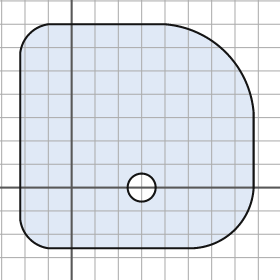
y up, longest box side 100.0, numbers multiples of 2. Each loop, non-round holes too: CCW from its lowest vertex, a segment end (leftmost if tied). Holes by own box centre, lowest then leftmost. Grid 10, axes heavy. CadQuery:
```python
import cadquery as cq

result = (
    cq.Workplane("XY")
    .moveTo(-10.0, -26.0)
    .lineTo(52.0, -26.0)
    .threePointArc((70.0, -18.0), (78.0, 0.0))
    .lineTo(78.0, 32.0)
    .threePointArc((66.0, 58.0), (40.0, 70.0))
    .lineTo(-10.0, 70.0)
    .threePointArc((-18.0, 66.0), (-22.0, 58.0))
    .lineTo(-22.0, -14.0)
    .threePointArc((-18.0, -22.0), (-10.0, -26.0))
    .close()
    .moveTo(30.0, 0.0)
    .circle(6.0)
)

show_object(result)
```